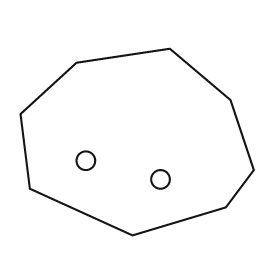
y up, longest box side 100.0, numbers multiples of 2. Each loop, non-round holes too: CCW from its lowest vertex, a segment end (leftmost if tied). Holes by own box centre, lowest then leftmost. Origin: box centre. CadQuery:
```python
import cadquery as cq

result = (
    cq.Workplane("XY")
    .moveTo(-2.0, -40.0)
    .lineTo(38.0, -28.0)
    .lineTo(50.0, -12.0)
    .lineTo(40.0, 18.0)
    .lineTo(14.0, 40.0)
    .lineTo(-26.0, 34.0)
    .lineTo(-50.0, 12.0)
    .lineTo(-46.0, -20.0)
    .close()
    .moveTo(10.0, -16.0)
    .circle(4.0)
    .moveTo(-22.0, -8.0)
    .circle(4.0)
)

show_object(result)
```